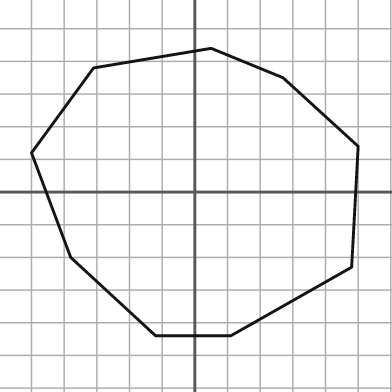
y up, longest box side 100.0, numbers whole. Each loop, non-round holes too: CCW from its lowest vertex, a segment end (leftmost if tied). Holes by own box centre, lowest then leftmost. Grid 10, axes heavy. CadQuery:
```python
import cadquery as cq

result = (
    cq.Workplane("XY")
    .moveTo(-12.0, -44.0)
    .lineTo(11.0, -44.0)
    .lineTo(48.0, -23.0)
    .lineTo(50.0, 14.0)
    .lineTo(27.0, 35.0)
    .lineTo(5.0, 44.0)
    .lineTo(-31.0, 38.0)
    .lineTo(-50.0, 12.0)
    .lineTo(-38.0, -20.0)
    .close()
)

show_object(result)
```